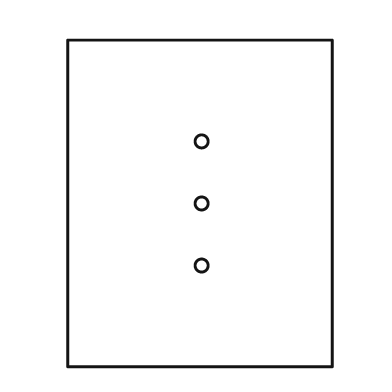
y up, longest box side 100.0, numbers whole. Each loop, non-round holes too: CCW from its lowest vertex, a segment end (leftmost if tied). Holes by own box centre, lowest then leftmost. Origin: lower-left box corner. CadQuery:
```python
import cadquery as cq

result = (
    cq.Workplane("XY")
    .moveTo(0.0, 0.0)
    .lineTo(81.0, 0.0)
    .lineTo(81.0, 100.0)
    .lineTo(0.0, 100.0)
    .close()
    .moveTo(41.0, 31.0)
    .circle(2.0)
    .moveTo(41.0, 50.0)
    .circle(2.0)
    .moveTo(41.0, 69.0)
    .circle(2.0)
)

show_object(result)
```